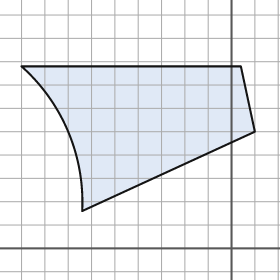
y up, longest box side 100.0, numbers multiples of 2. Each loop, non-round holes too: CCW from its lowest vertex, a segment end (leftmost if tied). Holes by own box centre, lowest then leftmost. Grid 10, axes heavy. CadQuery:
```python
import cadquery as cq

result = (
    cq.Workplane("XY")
    .moveTo(-64.0, 16.0)
    .lineTo(10.0, 50.0)
    .lineTo(4.0, 78.0)
    .lineTo(-90.0, 78.0)
    .threePointArc((-70.0, 50.0), (-64.0, 16.0))
    .close()
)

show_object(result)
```